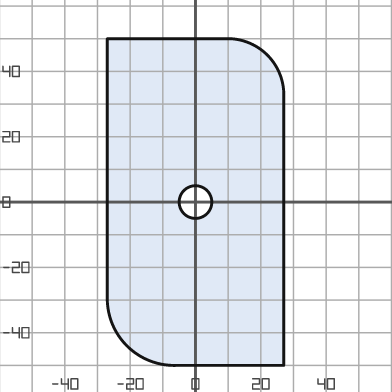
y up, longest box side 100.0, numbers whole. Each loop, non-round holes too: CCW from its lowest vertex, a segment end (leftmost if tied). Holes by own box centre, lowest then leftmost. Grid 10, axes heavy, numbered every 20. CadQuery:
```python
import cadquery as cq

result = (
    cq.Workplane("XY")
    .moveTo(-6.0, -50.0)
    .lineTo(27.0, -50.0)
    .lineTo(27.0, 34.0)
    .threePointArc((22.0, 45.0), (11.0, 50.0))
    .lineTo(-27.0, 50.0)
    .lineTo(-27.0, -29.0)
    .threePointArc((-21.0, -44.0), (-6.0, -50.0))
    .close()
    .moveTo(0.0, 0.0)
    .circle(5.0)
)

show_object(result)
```